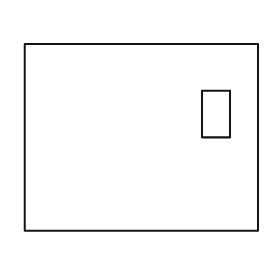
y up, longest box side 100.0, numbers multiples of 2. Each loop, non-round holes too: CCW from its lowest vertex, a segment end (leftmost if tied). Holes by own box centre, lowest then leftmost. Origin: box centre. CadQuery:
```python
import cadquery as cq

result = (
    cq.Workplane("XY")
    .moveTo(-50.0, -40.0)
    .lineTo(50.0, -40.0)
    .lineTo(50.0, 40.0)
    .lineTo(-50.0, 40.0)
    .close()
    .moveTo(26.0, 0.0)
    .lineTo(38.0, 0.0)
    .lineTo(38.0, 20.0)
    .lineTo(26.0, 20.0)
    .close()
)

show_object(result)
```